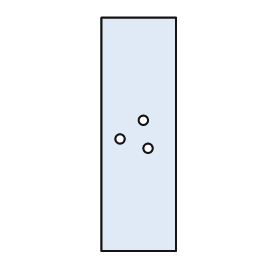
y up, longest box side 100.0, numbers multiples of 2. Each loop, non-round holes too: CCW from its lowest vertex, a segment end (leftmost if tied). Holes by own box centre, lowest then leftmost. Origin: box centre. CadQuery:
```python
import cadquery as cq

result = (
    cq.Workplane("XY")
    .moveTo(-16.0, -50.0)
    .lineTo(16.0, -50.0)
    .lineTo(16.0, 50.0)
    .lineTo(-16.0, 50.0)
    .close()
    .moveTo(4.0, -6.0)
    .circle(2.0)
    .moveTo(-8.0, -2.0)
    .circle(2.0)
    .moveTo(2.0, 6.0)
    .circle(2.0)
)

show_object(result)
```